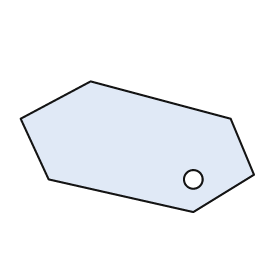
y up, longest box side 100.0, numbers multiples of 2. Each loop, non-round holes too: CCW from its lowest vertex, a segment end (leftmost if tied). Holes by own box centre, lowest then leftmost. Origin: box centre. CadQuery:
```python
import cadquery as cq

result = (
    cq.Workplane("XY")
    .moveTo(24.0, -28.0)
    .lineTo(50.0, -12.0)
    .lineTo(40.0, 12.0)
    .lineTo(-20.0, 28.0)
    .lineTo(-50.0, 12.0)
    .lineTo(-38.0, -14.0)
    .close()
    .moveTo(24.0, -14.0)
    .circle(4.0)
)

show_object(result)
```